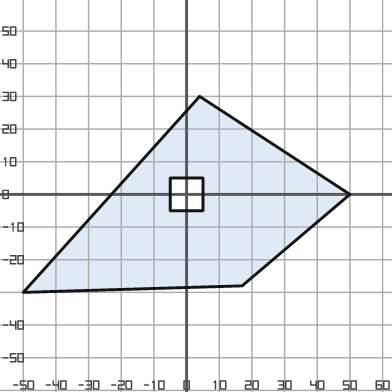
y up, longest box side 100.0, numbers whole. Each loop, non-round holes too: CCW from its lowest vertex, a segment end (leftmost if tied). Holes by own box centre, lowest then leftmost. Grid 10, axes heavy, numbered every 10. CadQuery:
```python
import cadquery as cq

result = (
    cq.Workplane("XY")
    .moveTo(-50.0, -30.0)
    .lineTo(17.0, -28.0)
    .lineTo(50.0, 0.0)
    .lineTo(4.0, 30.0)
    .close()
    .moveTo(-5.0, -5.0)
    .lineTo(5.0, -5.0)
    .lineTo(5.0, 5.0)
    .lineTo(-5.0, 5.0)
    .close()
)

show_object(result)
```